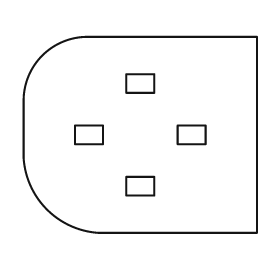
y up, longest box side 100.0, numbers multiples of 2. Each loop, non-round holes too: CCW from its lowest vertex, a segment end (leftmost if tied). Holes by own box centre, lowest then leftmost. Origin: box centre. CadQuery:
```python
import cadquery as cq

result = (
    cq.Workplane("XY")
    .moveTo(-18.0, -42.0)
    .lineTo(50.0, -42.0)
    .lineTo(50.0, 42.0)
    .lineTo(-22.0, 42.0)
    .threePointArc((-42.0, 34.0), (-50.0, 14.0))
    .lineTo(-50.0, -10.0)
    .threePointArc((-40.0, -32.0), (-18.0, -42.0))
    .close()
    .moveTo(-6.0, -26.0)
    .lineTo(6.0, -26.0)
    .lineTo(6.0, -18.0)
    .lineTo(-6.0, -18.0)
    .close()
    .moveTo(-28.0, -4.0)
    .lineTo(-16.0, -4.0)
    .lineTo(-16.0, 4.0)
    .lineTo(-28.0, 4.0)
    .close()
    .moveTo(16.0, -4.0)
    .lineTo(28.0, -4.0)
    .lineTo(28.0, 4.0)
    .lineTo(16.0, 4.0)
    .close()
    .moveTo(-6.0, 18.0)
    .lineTo(6.0, 18.0)
    .lineTo(6.0, 26.0)
    .lineTo(-6.0, 26.0)
    .close()
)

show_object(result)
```